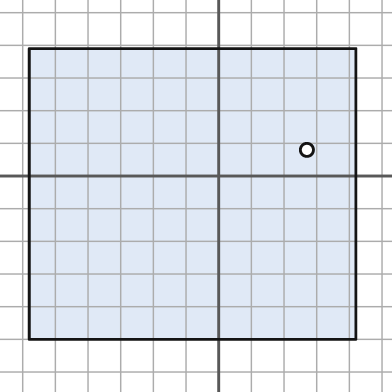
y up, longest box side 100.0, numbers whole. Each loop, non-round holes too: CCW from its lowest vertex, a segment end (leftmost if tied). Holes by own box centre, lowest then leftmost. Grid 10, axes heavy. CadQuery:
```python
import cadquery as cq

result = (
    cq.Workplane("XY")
    .moveTo(-58.0, -50.0)
    .lineTo(42.0, -50.0)
    .lineTo(42.0, 39.0)
    .lineTo(-58.0, 39.0)
    .close()
    .moveTo(27.0, 8.0)
    .circle(2.0)
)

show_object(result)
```